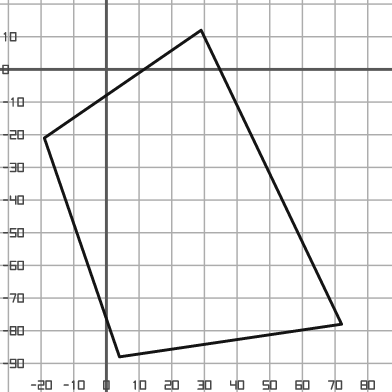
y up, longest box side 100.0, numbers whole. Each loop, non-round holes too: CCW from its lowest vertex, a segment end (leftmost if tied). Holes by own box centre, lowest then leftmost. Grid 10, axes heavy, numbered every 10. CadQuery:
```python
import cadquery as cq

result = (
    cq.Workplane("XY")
    .moveTo(4.0, -88.0)
    .lineTo(72.0, -78.0)
    .lineTo(29.0, 12.0)
    .lineTo(-19.0, -21.0)
    .close()
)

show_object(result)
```